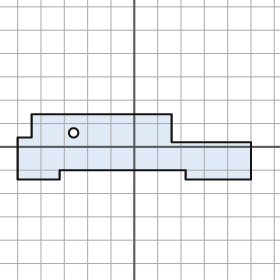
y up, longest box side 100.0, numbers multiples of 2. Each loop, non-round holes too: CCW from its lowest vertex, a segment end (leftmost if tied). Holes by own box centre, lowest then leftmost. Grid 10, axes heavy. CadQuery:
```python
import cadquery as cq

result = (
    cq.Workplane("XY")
    .moveTo(-50.0, -14.0)
    .lineTo(-32.0, -14.0)
    .lineTo(-32.0, -10.0)
    .lineTo(22.0, -10.0)
    .lineTo(22.0, -14.0)
    .lineTo(50.0, -14.0)
    .lineTo(50.0, 2.0)
    .lineTo(16.0, 2.0)
    .lineTo(16.0, 14.0)
    .lineTo(-44.0, 14.0)
    .lineTo(-44.0, 4.0)
    .lineTo(-50.0, 4.0)
    .close()
    .moveTo(-26.0, 6.0)
    .circle(2.0)
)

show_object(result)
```